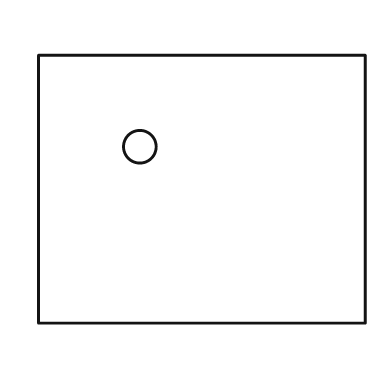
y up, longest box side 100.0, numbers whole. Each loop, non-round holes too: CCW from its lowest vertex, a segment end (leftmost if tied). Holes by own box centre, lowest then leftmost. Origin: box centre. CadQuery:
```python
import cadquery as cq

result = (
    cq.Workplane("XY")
    .moveTo(-50.0, -41.0)
    .lineTo(50.0, -41.0)
    .lineTo(50.0, 41.0)
    .lineTo(-50.0, 41.0)
    .close()
    .moveTo(-19.0, 13.0)
    .circle(5.0)
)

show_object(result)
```